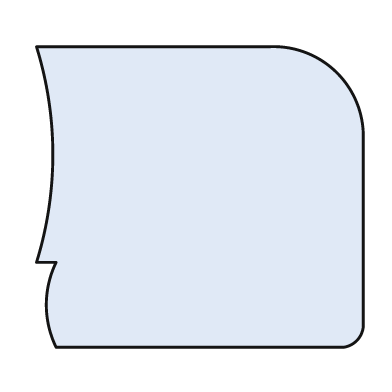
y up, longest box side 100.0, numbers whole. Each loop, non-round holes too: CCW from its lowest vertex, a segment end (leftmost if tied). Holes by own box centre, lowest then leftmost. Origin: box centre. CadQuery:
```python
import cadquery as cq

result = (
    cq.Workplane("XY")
    .moveTo(-44.0, -46.0)
    .lineTo(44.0, -46.0)
    .threePointArc((48.0, -44.0), (50.0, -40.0))
    .lineTo(50.0, 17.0)
    .threePointArc((42.0, 38.0), (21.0, 46.0))
    .lineTo(-50.0, 46.0)
    .threePointArc((-45.0, 13.0), (-50.0, -20.0))
    .lineTo(-44.0, -20.0)
    .threePointArc((-47.0, -33.0), (-44.0, -46.0))
    .close()
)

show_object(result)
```